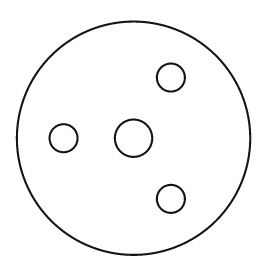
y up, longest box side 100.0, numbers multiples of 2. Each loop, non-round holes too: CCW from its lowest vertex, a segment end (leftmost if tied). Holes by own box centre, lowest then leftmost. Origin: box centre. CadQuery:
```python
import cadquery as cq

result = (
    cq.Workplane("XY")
    .moveTo(0.0, 0.0)
    .circle(50.0)
    .moveTo(16.0, -26.0)
    .circle(6.0)
    .moveTo(-30.0, 0.0)
    .circle(6.0)
    .moveTo(0.0, 0.0)
    .circle(8.0)
    .moveTo(16.0, 26.0)
    .circle(6.0)
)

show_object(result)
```